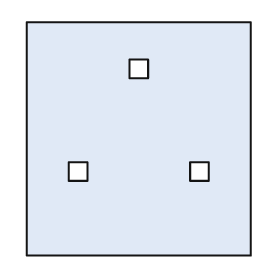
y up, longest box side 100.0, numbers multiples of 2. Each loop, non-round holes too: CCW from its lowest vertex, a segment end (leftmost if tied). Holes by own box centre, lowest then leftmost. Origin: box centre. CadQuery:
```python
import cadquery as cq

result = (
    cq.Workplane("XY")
    .moveTo(-48.0, -50.0)
    .lineTo(48.0, -50.0)
    .lineTo(48.0, 50.0)
    .lineTo(-48.0, 50.0)
    .close()
    .moveTo(-30.0, -18.0)
    .lineTo(-22.0, -18.0)
    .lineTo(-22.0, -10.0)
    .lineTo(-30.0, -10.0)
    .close()
    .moveTo(22.0, -18.0)
    .lineTo(30.0, -18.0)
    .lineTo(30.0, -10.0)
    .lineTo(22.0, -10.0)
    .close()
    .moveTo(-4.0, 26.0)
    .lineTo(4.0, 26.0)
    .lineTo(4.0, 34.0)
    .lineTo(-4.0, 34.0)
    .close()
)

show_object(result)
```